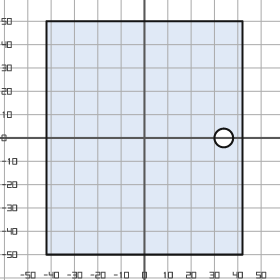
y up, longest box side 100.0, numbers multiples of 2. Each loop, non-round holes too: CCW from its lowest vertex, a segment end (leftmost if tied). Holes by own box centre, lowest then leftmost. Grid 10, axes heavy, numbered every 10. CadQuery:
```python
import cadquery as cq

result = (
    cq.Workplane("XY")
    .moveTo(-42.0, -50.0)
    .lineTo(42.0, -50.0)
    .lineTo(42.0, 50.0)
    .lineTo(-42.0, 50.0)
    .close()
    .moveTo(34.0, 0.0)
    .circle(4.0)
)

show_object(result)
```